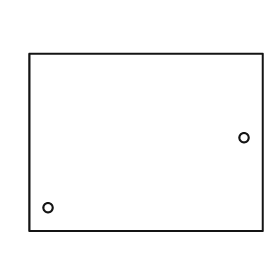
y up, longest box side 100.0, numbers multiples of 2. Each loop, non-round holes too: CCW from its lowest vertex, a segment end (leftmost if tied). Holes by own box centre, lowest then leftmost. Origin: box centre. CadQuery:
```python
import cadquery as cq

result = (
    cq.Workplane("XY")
    .moveTo(-50.0, -38.0)
    .lineTo(50.0, -38.0)
    .lineTo(50.0, 38.0)
    .lineTo(-50.0, 38.0)
    .close()
    .moveTo(-42.0, -28.0)
    .circle(2.0)
    .moveTo(42.0, 2.0)
    .circle(2.0)
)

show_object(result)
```